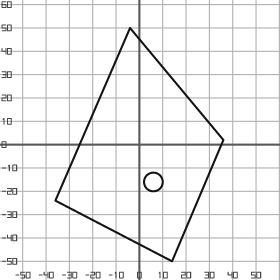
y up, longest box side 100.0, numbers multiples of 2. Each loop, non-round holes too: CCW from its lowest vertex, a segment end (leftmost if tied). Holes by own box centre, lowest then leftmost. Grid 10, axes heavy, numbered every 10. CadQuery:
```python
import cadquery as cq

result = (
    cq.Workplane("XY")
    .moveTo(14.0, -50.0)
    .lineTo(36.0, 2.0)
    .lineTo(-4.0, 50.0)
    .lineTo(-36.0, -24.0)
    .close()
    .moveTo(6.0, -16.0)
    .circle(4.0)
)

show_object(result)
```